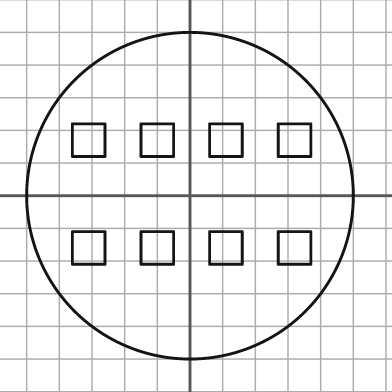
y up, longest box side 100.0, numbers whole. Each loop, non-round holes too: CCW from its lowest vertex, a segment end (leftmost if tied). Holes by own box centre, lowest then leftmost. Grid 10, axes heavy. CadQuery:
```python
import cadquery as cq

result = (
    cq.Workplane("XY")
    .moveTo(0.0, 0.0)
    .circle(50.0)
    .moveTo(-36.0, -21.0)
    .lineTo(-26.0, -21.0)
    .lineTo(-26.0, -11.0)
    .lineTo(-36.0, -11.0)
    .close()
    .moveTo(-15.0, -21.0)
    .lineTo(-5.0, -21.0)
    .lineTo(-5.0, -11.0)
    .lineTo(-15.0, -11.0)
    .close()
    .moveTo(6.0, -21.0)
    .lineTo(16.0, -21.0)
    .lineTo(16.0, -11.0)
    .lineTo(6.0, -11.0)
    .close()
    .moveTo(27.0, -21.0)
    .lineTo(37.0, -21.0)
    .lineTo(37.0, -11.0)
    .lineTo(27.0, -11.0)
    .close()
    .moveTo(-36.0, 12.0)
    .lineTo(-26.0, 12.0)
    .lineTo(-26.0, 22.0)
    .lineTo(-36.0, 22.0)
    .close()
    .moveTo(-15.0, 12.0)
    .lineTo(-5.0, 12.0)
    .lineTo(-5.0, 22.0)
    .lineTo(-15.0, 22.0)
    .close()
    .moveTo(6.0, 12.0)
    .lineTo(16.0, 12.0)
    .lineTo(16.0, 22.0)
    .lineTo(6.0, 22.0)
    .close()
    .moveTo(27.0, 12.0)
    .lineTo(37.0, 12.0)
    .lineTo(37.0, 22.0)
    .lineTo(27.0, 22.0)
    .close()
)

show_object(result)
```